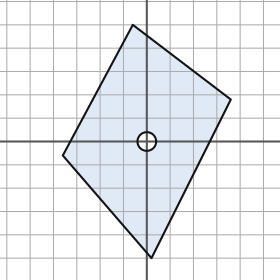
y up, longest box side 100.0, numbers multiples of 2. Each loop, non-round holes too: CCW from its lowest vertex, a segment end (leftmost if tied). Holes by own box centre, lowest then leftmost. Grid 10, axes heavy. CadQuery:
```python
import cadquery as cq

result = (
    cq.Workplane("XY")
    .moveTo(2.0, -50.0)
    .lineTo(36.0, 18.0)
    .lineTo(-6.0, 50.0)
    .lineTo(-36.0, -6.0)
    .close()
    .moveTo(0.0, 0.0)
    .circle(4.0)
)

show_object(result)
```